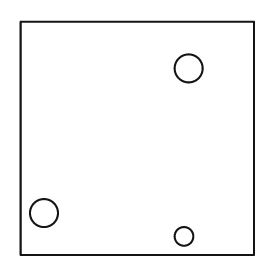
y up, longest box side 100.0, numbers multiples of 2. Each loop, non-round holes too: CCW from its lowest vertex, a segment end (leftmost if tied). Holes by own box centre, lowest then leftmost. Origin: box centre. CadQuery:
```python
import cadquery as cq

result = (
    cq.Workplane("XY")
    .moveTo(-50.0, -50.0)
    .lineTo(50.0, -50.0)
    .lineTo(50.0, 50.0)
    .lineTo(-50.0, 50.0)
    .close()
    .moveTo(20.0, -42.0)
    .circle(4.0)
    .moveTo(-40.0, -32.0)
    .circle(6.0)
    .moveTo(22.0, 30.0)
    .circle(6.0)
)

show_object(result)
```